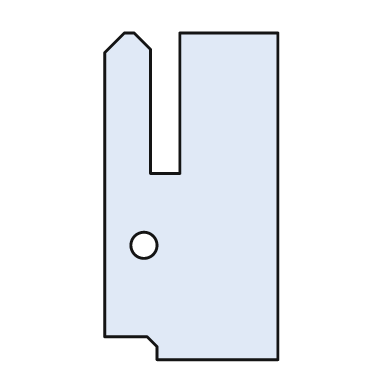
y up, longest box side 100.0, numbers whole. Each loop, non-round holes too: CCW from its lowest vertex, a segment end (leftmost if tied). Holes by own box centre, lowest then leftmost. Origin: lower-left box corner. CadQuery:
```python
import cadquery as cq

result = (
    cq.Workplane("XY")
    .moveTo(16.0, 0.0)
    .lineTo(53.0, 0.0)
    .lineTo(53.0, 100.0)
    .lineTo(23.0, 100.0)
    .lineTo(23.0, 57.0)
    .lineTo(14.0, 57.0)
    .lineTo(14.0, 95.0)
    .lineTo(9.0, 100.0)
    .lineTo(6.0, 100.0)
    .lineTo(0.0, 94.0)
    .lineTo(0.0, 7.0)
    .lineTo(13.0, 7.0)
    .lineTo(16.0, 4.0)
    .close()
    .moveTo(12.0, 35.0)
    .circle(4.0)
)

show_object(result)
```